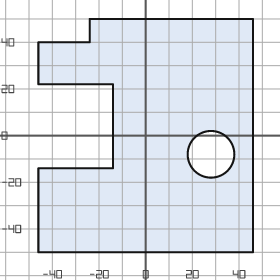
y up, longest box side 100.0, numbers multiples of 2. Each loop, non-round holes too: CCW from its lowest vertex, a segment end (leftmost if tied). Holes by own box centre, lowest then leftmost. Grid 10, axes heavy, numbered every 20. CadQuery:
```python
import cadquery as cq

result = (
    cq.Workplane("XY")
    .moveTo(-46.0, -50.0)
    .lineTo(46.0, -50.0)
    .lineTo(46.0, 50.0)
    .lineTo(-24.0, 50.0)
    .lineTo(-24.0, 40.0)
    .lineTo(-46.0, 40.0)
    .lineTo(-46.0, 22.0)
    .lineTo(-14.0, 22.0)
    .lineTo(-14.0, -14.0)
    .lineTo(-46.0, -14.0)
    .close()
    .moveTo(28.0, -8.0)
    .circle(10.0)
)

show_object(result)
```